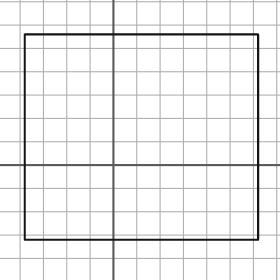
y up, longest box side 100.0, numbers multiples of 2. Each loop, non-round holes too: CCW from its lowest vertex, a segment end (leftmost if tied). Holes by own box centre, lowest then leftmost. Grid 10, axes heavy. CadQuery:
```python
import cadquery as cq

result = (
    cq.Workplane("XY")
    .moveTo(-38.0, -32.0)
    .lineTo(62.0, -32.0)
    .lineTo(62.0, 56.0)
    .lineTo(-38.0, 56.0)
    .close()
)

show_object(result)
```